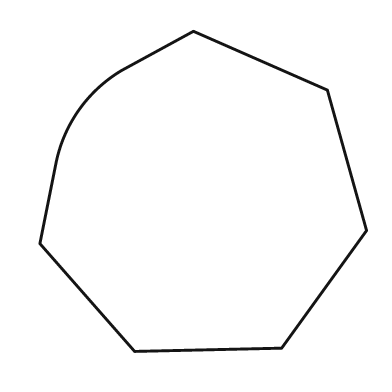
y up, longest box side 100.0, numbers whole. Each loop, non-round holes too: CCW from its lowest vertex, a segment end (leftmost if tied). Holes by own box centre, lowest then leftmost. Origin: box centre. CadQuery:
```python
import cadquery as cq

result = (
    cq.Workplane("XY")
    .moveTo(-21.0, -49.0)
    .lineTo(24.0, -48.0)
    .lineTo(50.0, -12.0)
    .lineTo(38.0, 31.0)
    .lineTo(-3.0, 49.0)
    .lineTo(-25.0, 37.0)
    .threePointArc((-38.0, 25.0), (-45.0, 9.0))
    .lineTo(-50.0, -16.0)
    .close()
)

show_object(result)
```